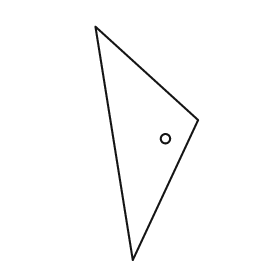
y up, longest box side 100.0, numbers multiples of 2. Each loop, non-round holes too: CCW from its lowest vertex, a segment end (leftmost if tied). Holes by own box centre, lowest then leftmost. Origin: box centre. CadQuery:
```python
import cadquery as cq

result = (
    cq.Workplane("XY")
    .moveTo(-6.0, -50.0)
    .lineTo(22.0, 10.0)
    .lineTo(-22.0, 50.0)
    .close()
    .moveTo(8.0, 2.0)
    .circle(2.0)
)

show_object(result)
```